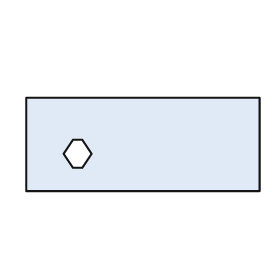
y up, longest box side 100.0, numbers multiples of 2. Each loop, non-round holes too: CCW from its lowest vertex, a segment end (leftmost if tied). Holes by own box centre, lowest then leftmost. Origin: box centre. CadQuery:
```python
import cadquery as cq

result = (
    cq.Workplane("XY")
    .moveTo(-50.0, -20.0)
    .lineTo(50.0, -20.0)
    .lineTo(50.0, 20.0)
    .lineTo(-50.0, 20.0)
    .close()
    .moveTo(-30.0, -10.0)
    .lineTo(-26.0, -10.0)
    .lineTo(-22.0, -4.0)
    .lineTo(-26.0, 2.0)
    .lineTo(-30.0, 2.0)
    .lineTo(-34.0, -4.0)
    .close()
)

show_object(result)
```